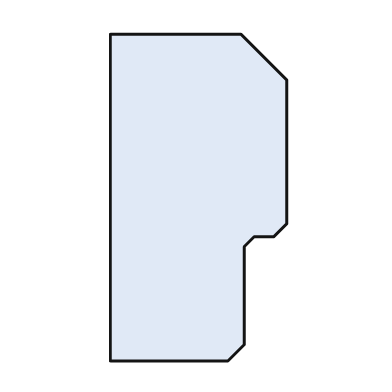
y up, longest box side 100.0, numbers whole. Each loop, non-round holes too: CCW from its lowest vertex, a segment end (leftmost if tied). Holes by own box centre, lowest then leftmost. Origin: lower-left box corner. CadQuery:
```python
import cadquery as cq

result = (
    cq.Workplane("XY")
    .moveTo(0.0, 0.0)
    .lineTo(36.0, 0.0)
    .lineTo(41.0, 5.0)
    .lineTo(41.0, 35.0)
    .lineTo(44.0, 38.0)
    .lineTo(50.0, 38.0)
    .lineTo(54.0, 42.0)
    .lineTo(54.0, 86.0)
    .lineTo(40.0, 100.0)
    .lineTo(0.0, 100.0)
    .close()
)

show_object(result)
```